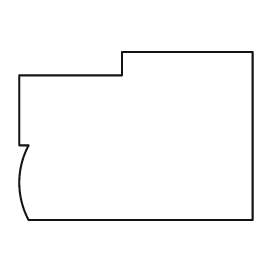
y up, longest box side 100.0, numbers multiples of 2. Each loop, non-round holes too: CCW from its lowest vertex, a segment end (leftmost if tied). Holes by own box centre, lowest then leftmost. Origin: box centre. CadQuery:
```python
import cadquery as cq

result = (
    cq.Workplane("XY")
    .moveTo(-46.0, -36.0)
    .lineTo(50.0, -36.0)
    .lineTo(50.0, 36.0)
    .lineTo(-6.0, 36.0)
    .lineTo(-6.0, 26.0)
    .lineTo(-50.0, 26.0)
    .lineTo(-50.0, -4.0)
    .lineTo(-46.0, -4.0)
    .threePointArc((-50.0, -20.0), (-46.0, -36.0))
    .close()
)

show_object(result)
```